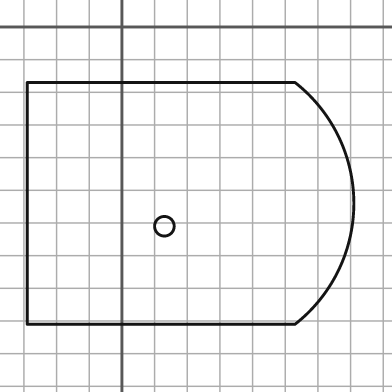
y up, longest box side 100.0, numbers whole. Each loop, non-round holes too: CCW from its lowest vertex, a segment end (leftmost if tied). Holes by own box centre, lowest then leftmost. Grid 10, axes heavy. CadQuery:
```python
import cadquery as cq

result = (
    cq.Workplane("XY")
    .moveTo(-29.0, -91.0)
    .lineTo(53.0, -91.0)
    .threePointArc((71.0, -54.0), (53.0, -17.0))
    .lineTo(-29.0, -17.0)
    .close()
    .moveTo(13.0, -61.0)
    .circle(3.0)
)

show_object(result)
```